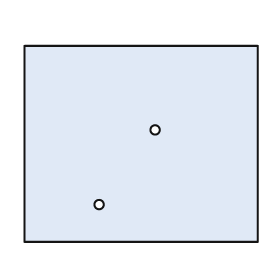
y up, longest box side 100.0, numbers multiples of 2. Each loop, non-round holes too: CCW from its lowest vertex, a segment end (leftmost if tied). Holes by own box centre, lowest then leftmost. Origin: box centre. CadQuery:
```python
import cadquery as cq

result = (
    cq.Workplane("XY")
    .moveTo(-50.0, -42.0)
    .lineTo(50.0, -42.0)
    .lineTo(50.0, 42.0)
    .lineTo(-50.0, 42.0)
    .close()
    .moveTo(-18.0, -26.0)
    .circle(2.0)
    .moveTo(6.0, 6.0)
    .circle(2.0)
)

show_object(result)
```